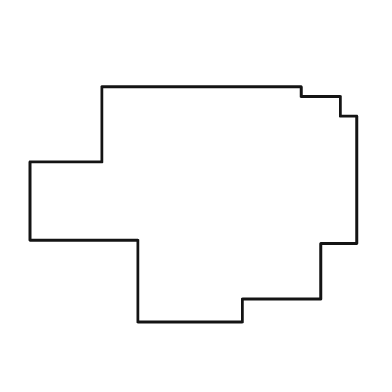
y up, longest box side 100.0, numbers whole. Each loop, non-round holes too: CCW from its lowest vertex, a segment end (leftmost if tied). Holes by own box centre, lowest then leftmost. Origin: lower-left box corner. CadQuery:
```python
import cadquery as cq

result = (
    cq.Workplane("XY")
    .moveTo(33.0, 0.0)
    .lineTo(65.0, 0.0)
    .lineTo(65.0, 7.0)
    .lineTo(89.0, 7.0)
    .lineTo(89.0, 24.0)
    .lineTo(100.0, 24.0)
    .lineTo(100.0, 63.0)
    .lineTo(95.0, 63.0)
    .lineTo(95.0, 69.0)
    .lineTo(83.0, 69.0)
    .lineTo(83.0, 72.0)
    .lineTo(22.0, 72.0)
    .lineTo(22.0, 49.0)
    .lineTo(0.0, 49.0)
    .lineTo(0.0, 25.0)
    .lineTo(33.0, 25.0)
    .close()
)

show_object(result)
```